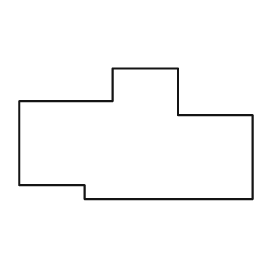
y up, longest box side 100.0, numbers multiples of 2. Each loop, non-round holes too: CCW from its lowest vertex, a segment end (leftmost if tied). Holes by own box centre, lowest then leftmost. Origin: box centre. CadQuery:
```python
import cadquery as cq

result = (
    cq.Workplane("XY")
    .moveTo(-22.0, -28.0)
    .lineTo(50.0, -28.0)
    .lineTo(50.0, 8.0)
    .lineTo(18.0, 8.0)
    .lineTo(18.0, 28.0)
    .lineTo(-10.0, 28.0)
    .lineTo(-10.0, 14.0)
    .lineTo(-50.0, 14.0)
    .lineTo(-50.0, -22.0)
    .lineTo(-22.0, -22.0)
    .close()
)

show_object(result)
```